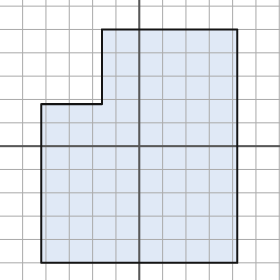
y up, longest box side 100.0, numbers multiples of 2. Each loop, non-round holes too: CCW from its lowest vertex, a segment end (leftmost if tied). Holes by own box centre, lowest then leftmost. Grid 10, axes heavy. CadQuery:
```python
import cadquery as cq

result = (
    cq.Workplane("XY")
    .moveTo(-42.0, -50.0)
    .lineTo(42.0, -50.0)
    .lineTo(42.0, 50.0)
    .lineTo(-16.0, 50.0)
    .lineTo(-16.0, 18.0)
    .lineTo(-42.0, 18.0)
    .close()
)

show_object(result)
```